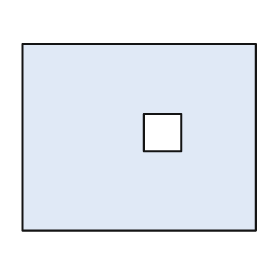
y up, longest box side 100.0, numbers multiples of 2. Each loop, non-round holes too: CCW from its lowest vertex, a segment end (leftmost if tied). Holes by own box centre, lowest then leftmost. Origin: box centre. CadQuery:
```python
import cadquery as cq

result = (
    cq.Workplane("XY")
    .moveTo(-50.0, -40.0)
    .lineTo(50.0, -40.0)
    .lineTo(50.0, 40.0)
    .lineTo(-50.0, 40.0)
    .close()
    .moveTo(2.0, -6.0)
    .lineTo(18.0, -6.0)
    .lineTo(18.0, 10.0)
    .lineTo(2.0, 10.0)
    .close()
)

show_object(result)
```